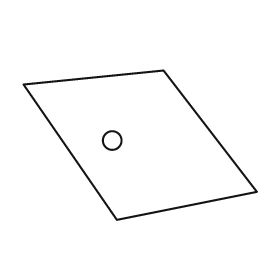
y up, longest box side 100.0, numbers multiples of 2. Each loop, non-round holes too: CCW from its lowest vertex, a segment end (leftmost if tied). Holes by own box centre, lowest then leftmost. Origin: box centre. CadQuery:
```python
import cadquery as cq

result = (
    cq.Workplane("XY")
    .moveTo(-10.0, -32.0)
    .lineTo(50.0, -20.0)
    .lineTo(10.0, 32.0)
    .lineTo(-50.0, 26.0)
    .close()
    .moveTo(-12.0, 2.0)
    .circle(4.0)
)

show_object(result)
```